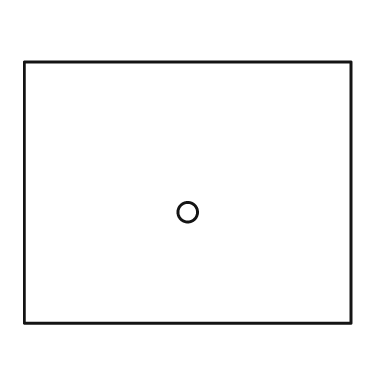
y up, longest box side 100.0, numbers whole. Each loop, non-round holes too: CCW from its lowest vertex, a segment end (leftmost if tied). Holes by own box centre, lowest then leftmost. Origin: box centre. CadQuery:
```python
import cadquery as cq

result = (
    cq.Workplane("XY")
    .moveTo(-50.0, -40.0)
    .lineTo(50.0, -40.0)
    .lineTo(50.0, 40.0)
    .lineTo(-50.0, 40.0)
    .close()
    .moveTo(0.0, -6.0)
    .circle(3.0)
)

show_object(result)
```